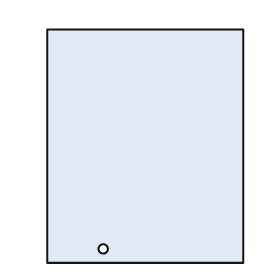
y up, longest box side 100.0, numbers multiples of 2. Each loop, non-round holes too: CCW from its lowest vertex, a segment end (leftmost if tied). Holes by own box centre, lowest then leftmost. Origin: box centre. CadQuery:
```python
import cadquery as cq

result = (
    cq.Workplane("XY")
    .moveTo(-42.0, -50.0)
    .lineTo(42.0, -50.0)
    .lineTo(42.0, 50.0)
    .lineTo(-42.0, 50.0)
    .close()
    .moveTo(-18.0, -44.0)
    .circle(2.0)
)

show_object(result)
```